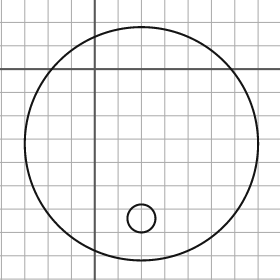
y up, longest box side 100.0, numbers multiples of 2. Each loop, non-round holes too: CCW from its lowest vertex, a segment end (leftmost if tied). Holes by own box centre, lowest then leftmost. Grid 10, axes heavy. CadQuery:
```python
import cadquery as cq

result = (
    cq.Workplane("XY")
    .moveTo(20.0, -32.0)
    .circle(50.0)
    .moveTo(20.0, -64.0)
    .circle(6.0)
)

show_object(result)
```